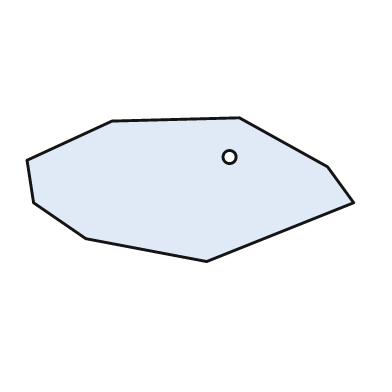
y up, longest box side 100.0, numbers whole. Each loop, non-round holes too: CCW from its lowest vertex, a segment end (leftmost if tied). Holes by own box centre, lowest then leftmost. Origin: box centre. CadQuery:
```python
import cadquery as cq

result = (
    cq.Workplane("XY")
    .moveTo(5.0, -22.0)
    .lineTo(50.0, -4.0)
    .lineTo(42.0, 7.0)
    .lineTo(15.0, 22.0)
    .lineTo(-24.0, 21.0)
    .lineTo(-50.0, 9.0)
    .lineTo(-48.0, -4.0)
    .lineTo(-32.0, -15.0)
    .close()
    .moveTo(12.0, 10.0)
    .circle(2.0)
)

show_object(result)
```